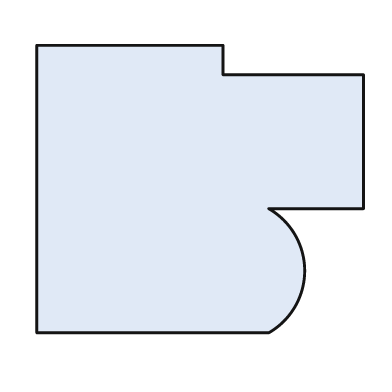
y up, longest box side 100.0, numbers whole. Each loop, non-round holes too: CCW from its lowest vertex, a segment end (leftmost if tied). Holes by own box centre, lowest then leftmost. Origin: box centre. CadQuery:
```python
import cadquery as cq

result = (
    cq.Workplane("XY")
    .moveTo(-50.0, -44.0)
    .lineTo(21.0, -44.0)
    .threePointArc((32.0, -25.0), (21.0, -6.0))
    .lineTo(50.0, -6.0)
    .lineTo(50.0, 35.0)
    .lineTo(7.0, 35.0)
    .lineTo(7.0, 44.0)
    .lineTo(-50.0, 44.0)
    .close()
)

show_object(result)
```